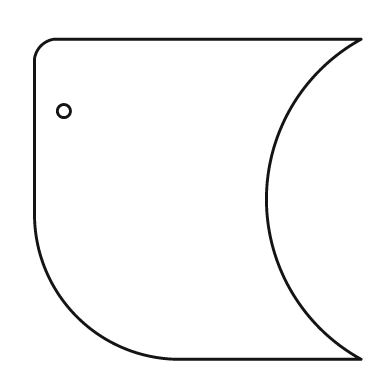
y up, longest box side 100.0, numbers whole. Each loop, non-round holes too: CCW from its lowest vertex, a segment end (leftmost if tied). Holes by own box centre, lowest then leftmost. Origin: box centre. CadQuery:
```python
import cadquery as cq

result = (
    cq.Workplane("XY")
    .moveTo(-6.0, -49.0)
    .lineTo(50.0, -49.0)
    .threePointArc((21.0, 0.0), (50.0, 49.0))
    .lineTo(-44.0, 49.0)
    .threePointArc((-48.0, 47.0), (-50.0, 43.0))
    .lineTo(-50.0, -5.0)
    .threePointArc((-37.0, -36.0), (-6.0, -49.0))
    .close()
    .moveTo(-41.0, 27.0)
    .circle(2.0)
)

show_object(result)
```